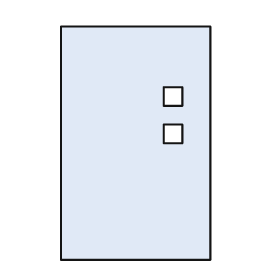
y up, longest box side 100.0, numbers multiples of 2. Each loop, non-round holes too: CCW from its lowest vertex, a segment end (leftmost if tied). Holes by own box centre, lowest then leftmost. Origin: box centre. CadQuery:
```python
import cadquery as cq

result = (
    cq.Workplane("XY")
    .moveTo(-32.0, -50.0)
    .lineTo(32.0, -50.0)
    .lineTo(32.0, 50.0)
    .lineTo(-32.0, 50.0)
    .close()
    .moveTo(12.0, 0.0)
    .lineTo(20.0, 0.0)
    .lineTo(20.0, 8.0)
    .lineTo(12.0, 8.0)
    .close()
    .moveTo(12.0, 16.0)
    .lineTo(20.0, 16.0)
    .lineTo(20.0, 24.0)
    .lineTo(12.0, 24.0)
    .close()
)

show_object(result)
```